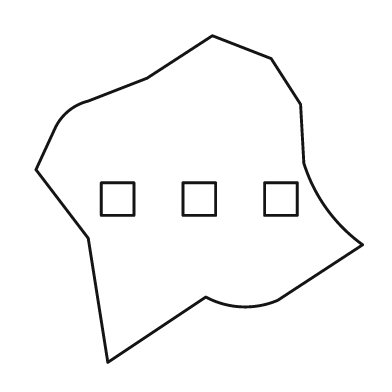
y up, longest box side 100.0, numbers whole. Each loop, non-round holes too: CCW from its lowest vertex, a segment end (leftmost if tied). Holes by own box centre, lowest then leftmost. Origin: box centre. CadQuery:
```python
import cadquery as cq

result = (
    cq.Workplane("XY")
    .moveTo(-28.0, -50.0)
    .lineTo(2.0, -30.0)
    .threePointArc((13.0, -33.0), (24.0, -31.0))
    .lineTo(50.0, -14.0)
    .threePointArc((39.0, -3.0), (32.0, 11.0))
    .lineTo(31.0, 29.0)
    .lineTo(22.0, 43.0)
    .lineTo(4.0, 50.0)
    .lineTo(-16.0, 37.0)
    .lineTo(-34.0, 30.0)
    .threePointArc((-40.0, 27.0), (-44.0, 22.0))
    .lineTo(-50.0, 9.0)
    .lineTo(-34.0, -12.0)
    .close()
    .moveTo(-30.0, -5.0)
    .lineTo(-20.0, -5.0)
    .lineTo(-20.0, 5.0)
    .lineTo(-30.0, 5.0)
    .close()
    .moveTo(-5.0, -5.0)
    .lineTo(5.0, -5.0)
    .lineTo(5.0, 5.0)
    .lineTo(-5.0, 5.0)
    .close()
    .moveTo(20.0, -5.0)
    .lineTo(30.0, -5.0)
    .lineTo(30.0, 5.0)
    .lineTo(20.0, 5.0)
    .close()
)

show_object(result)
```